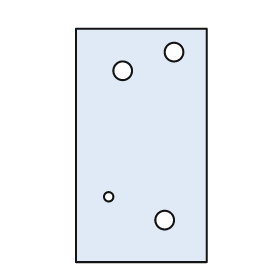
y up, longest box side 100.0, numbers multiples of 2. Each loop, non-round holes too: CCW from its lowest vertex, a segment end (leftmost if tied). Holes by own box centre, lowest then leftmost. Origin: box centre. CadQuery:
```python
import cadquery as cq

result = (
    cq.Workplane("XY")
    .moveTo(-28.0, -50.0)
    .lineTo(28.0, -50.0)
    .lineTo(28.0, 50.0)
    .lineTo(-28.0, 50.0)
    .close()
    .moveTo(10.0, -32.0)
    .circle(4.0)
    .moveTo(-14.0, -22.0)
    .circle(2.0)
    .moveTo(-8.0, 32.0)
    .circle(4.0)
    .moveTo(14.0, 40.0)
    .circle(4.0)
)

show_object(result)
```